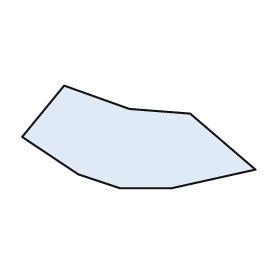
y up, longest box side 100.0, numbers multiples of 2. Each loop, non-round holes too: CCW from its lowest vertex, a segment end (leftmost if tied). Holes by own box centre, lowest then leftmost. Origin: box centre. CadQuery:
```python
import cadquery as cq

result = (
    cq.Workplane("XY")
    .moveTo(-8.0, -22.0)
    .lineTo(14.0, -22.0)
    .lineTo(50.0, -14.0)
    .lineTo(22.0, 10.0)
    .lineTo(-4.0, 12.0)
    .lineTo(-32.0, 22.0)
    .lineTo(-50.0, 0.0)
    .lineTo(-26.0, -16.0)
    .close()
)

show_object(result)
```